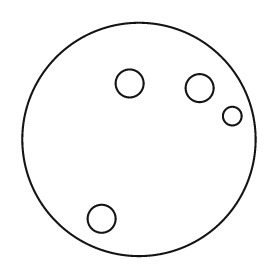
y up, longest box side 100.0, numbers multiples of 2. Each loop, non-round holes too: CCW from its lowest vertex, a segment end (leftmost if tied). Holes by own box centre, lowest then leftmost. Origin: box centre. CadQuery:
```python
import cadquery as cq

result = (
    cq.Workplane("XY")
    .moveTo(0.0, 0.0)
    .circle(50.0)
    .moveTo(-16.0, -34.0)
    .circle(6.0)
    .moveTo(40.0, 10.0)
    .circle(4.0)
    .moveTo(26.0, 22.0)
    .circle(6.0)
    .moveTo(-4.0, 24.0)
    .circle(6.0)
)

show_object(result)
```